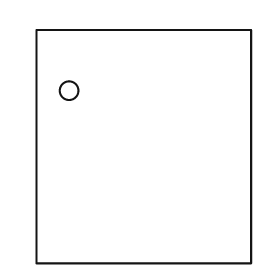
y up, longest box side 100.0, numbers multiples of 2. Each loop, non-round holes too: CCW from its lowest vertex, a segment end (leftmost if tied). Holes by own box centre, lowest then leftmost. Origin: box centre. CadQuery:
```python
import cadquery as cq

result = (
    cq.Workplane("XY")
    .moveTo(-46.0, -50.0)
    .lineTo(46.0, -50.0)
    .lineTo(46.0, 50.0)
    .lineTo(-46.0, 50.0)
    .close()
    .moveTo(-32.0, 24.0)
    .circle(4.0)
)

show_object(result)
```